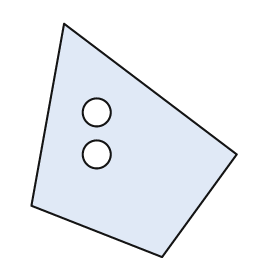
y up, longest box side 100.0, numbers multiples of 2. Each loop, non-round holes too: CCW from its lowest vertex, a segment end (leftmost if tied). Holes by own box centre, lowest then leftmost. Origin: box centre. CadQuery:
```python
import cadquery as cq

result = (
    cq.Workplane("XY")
    .moveTo(12.0, -50.0)
    .lineTo(44.0, -6.0)
    .lineTo(-30.0, 50.0)
    .lineTo(-44.0, -28.0)
    .close()
    .moveTo(-16.0, -6.0)
    .circle(6.0)
    .moveTo(-16.0, 12.0)
    .circle(6.0)
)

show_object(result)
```